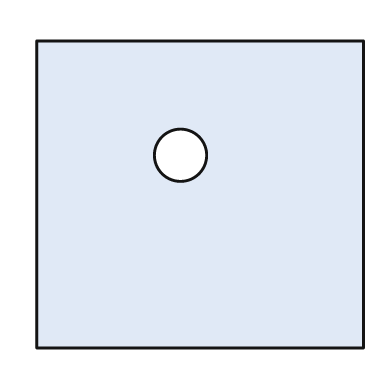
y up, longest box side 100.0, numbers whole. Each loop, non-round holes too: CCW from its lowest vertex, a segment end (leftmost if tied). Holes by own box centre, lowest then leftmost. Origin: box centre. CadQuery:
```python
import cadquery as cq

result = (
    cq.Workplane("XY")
    .moveTo(-50.0, -47.0)
    .lineTo(50.0, -47.0)
    .lineTo(50.0, 47.0)
    .lineTo(-50.0, 47.0)
    .close()
    .moveTo(-6.0, 12.0)
    .circle(8.0)
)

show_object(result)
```